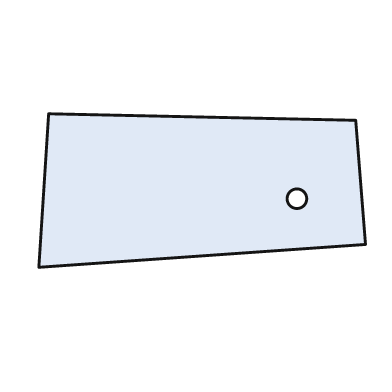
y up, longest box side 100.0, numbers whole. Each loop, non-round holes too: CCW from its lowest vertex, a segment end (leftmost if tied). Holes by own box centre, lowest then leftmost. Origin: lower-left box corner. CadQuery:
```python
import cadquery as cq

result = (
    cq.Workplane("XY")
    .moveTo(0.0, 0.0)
    .lineTo(100.0, 7.0)
    .lineTo(97.0, 45.0)
    .lineTo(3.0, 47.0)
    .close()
    .moveTo(79.0, 21.0)
    .circle(3.0)
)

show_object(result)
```